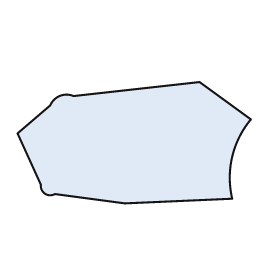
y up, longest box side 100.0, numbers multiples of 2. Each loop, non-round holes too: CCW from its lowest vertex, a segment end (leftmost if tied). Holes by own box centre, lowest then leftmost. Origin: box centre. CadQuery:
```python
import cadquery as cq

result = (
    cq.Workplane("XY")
    .moveTo(-4.0, -26.0)
    .lineTo(42.0, -24.0)
    .threePointArc((42.0, -6.0), (50.0, 10.0))
    .lineTo(28.0, 26.0)
    .lineTo(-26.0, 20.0)
    .threePointArc((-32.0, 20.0), (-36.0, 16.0))
    .lineTo(-50.0, 4.0)
    .lineTo(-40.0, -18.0)
    .threePointArc((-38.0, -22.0), (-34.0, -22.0))
    .close()
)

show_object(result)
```